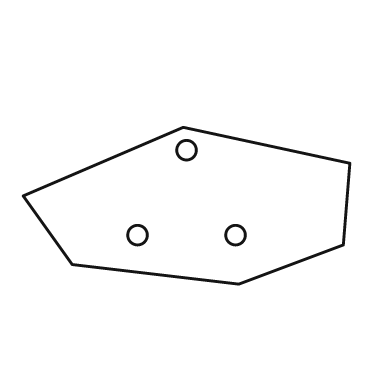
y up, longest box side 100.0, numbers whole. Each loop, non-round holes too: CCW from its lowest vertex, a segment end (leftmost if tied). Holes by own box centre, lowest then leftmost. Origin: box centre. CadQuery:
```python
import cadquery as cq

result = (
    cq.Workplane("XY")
    .moveTo(16.0, -24.0)
    .lineTo(48.0, -12.0)
    .lineTo(50.0, 13.0)
    .lineTo(-1.0, 24.0)
    .lineTo(-50.0, 3.0)
    .lineTo(-35.0, -18.0)
    .close()
    .moveTo(-15.0, -9.0)
    .circle(3.0)
    .moveTo(15.0, -9.0)
    .circle(3.0)
    .moveTo(0.0, 17.0)
    .circle(3.0)
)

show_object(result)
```